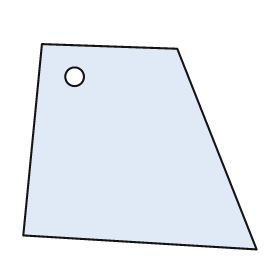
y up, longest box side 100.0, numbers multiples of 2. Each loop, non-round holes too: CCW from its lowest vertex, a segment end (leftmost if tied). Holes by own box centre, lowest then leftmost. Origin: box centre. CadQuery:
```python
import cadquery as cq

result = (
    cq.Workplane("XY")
    .moveTo(50.0, -44.0)
    .lineTo(16.0, 42.0)
    .lineTo(-42.0, 44.0)
    .lineTo(-50.0, -38.0)
    .close()
    .moveTo(-28.0, 30.0)
    .circle(4.0)
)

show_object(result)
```